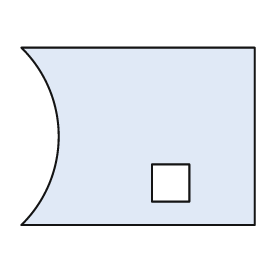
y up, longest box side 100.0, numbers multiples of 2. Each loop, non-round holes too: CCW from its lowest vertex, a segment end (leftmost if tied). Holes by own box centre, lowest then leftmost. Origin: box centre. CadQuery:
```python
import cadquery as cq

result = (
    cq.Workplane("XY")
    .moveTo(-50.0, -38.0)
    .lineTo(50.0, -38.0)
    .lineTo(50.0, 38.0)
    .lineTo(-50.0, 38.0)
    .threePointArc((-34.0, 0.0), (-50.0, -38.0))
    .close()
    .moveTo(6.0, -28.0)
    .lineTo(22.0, -28.0)
    .lineTo(22.0, -12.0)
    .lineTo(6.0, -12.0)
    .close()
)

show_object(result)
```